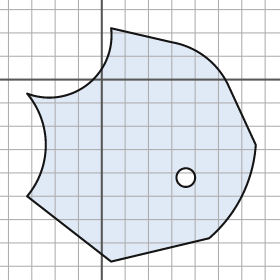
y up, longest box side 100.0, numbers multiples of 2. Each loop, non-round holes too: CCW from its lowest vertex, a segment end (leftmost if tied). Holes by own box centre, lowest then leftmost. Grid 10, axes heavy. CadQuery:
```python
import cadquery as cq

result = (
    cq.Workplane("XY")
    .moveTo(4.0, -78.0)
    .lineTo(46.0, -68.0)
    .threePointArc((60.0, -50.0), (66.0, -28.0))
    .lineTo(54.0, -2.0)
    .threePointArc((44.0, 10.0), (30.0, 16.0))
    .lineTo(4.0, 22.0)
    .threePointArc((-6.0, -2.0), (-32.0, -6.0))
    .threePointArc((-24.0, -28.0), (-32.0, -50.0))
    .close()
    .moveTo(36.0, -42.0)
    .circle(4.0)
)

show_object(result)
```